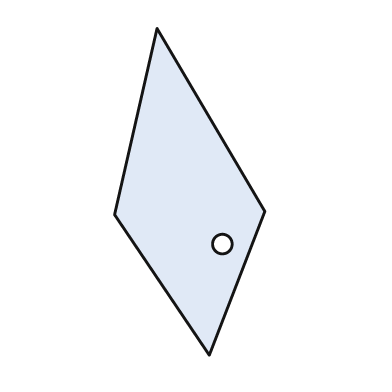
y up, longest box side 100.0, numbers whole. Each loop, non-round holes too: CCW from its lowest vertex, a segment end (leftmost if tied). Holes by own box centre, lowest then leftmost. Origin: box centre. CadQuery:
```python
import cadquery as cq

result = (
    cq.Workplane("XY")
    .moveTo(6.0, -50.0)
    .lineTo(23.0, -6.0)
    .lineTo(-10.0, 50.0)
    .lineTo(-23.0, -7.0)
    .close()
    .moveTo(10.0, -16.0)
    .circle(3.0)
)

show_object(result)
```